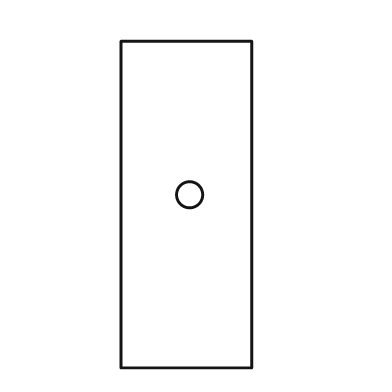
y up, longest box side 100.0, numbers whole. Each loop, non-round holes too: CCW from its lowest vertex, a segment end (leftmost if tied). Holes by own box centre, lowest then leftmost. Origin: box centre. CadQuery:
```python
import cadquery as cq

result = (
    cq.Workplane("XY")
    .moveTo(-20.0, -50.0)
    .lineTo(20.0, -50.0)
    .lineTo(20.0, 50.0)
    .lineTo(-20.0, 50.0)
    .close()
    .moveTo(1.0, 3.0)
    .circle(4.0)
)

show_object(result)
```